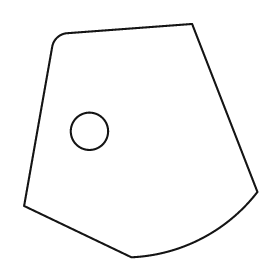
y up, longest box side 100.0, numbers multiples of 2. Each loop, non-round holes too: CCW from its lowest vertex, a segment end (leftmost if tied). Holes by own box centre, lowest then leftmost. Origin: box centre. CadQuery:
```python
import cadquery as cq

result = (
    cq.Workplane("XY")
    .moveTo(-4.0, -50.0)
    .threePointArc((26.0, -42.0), (50.0, -22.0))
    .lineTo(22.0, 50.0)
    .lineTo(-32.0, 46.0)
    .threePointArc((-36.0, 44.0), (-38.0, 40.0))
    .lineTo(-50.0, -28.0)
    .close()
    .moveTo(-22.0, 4.0)
    .circle(8.0)
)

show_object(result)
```